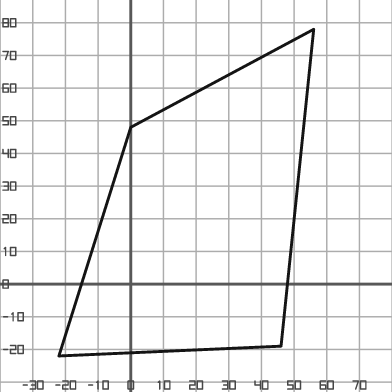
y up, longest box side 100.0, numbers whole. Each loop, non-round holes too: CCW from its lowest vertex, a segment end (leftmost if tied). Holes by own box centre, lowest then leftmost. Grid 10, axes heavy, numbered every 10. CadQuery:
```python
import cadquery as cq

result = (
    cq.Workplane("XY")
    .moveTo(-22.0, -22.0)
    .lineTo(46.0, -19.0)
    .lineTo(56.0, 78.0)
    .lineTo(0.0, 48.0)
    .close()
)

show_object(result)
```